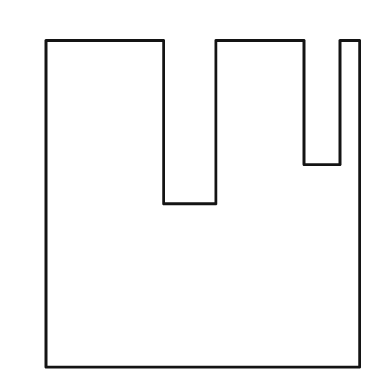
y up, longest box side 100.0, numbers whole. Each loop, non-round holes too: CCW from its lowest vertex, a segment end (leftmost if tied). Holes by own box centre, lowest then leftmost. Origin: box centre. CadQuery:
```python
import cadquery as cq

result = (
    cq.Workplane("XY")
    .moveTo(-48.0, -50.0)
    .lineTo(48.0, -50.0)
    .lineTo(48.0, 50.0)
    .lineTo(42.0, 50.0)
    .lineTo(42.0, 12.0)
    .lineTo(31.0, 12.0)
    .lineTo(31.0, 50.0)
    .lineTo(4.0, 50.0)
    .lineTo(4.0, 0.0)
    .lineTo(-12.0, 0.0)
    .lineTo(-12.0, 50.0)
    .lineTo(-48.0, 50.0)
    .close()
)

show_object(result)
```